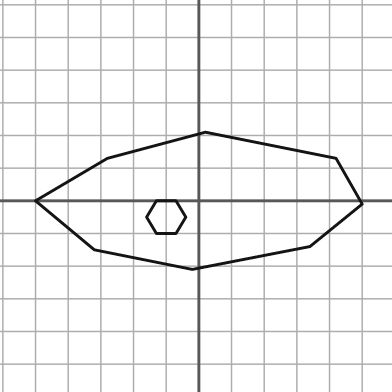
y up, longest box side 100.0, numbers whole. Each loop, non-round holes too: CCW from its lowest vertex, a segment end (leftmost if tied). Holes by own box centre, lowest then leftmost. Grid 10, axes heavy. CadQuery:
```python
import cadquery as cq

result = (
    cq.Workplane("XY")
    .moveTo(-2.0, -21.0)
    .lineTo(34.0, -14.0)
    .lineTo(50.0, -1.0)
    .lineTo(42.0, 13.0)
    .lineTo(2.0, 21.0)
    .lineTo(-28.0, 13.0)
    .lineTo(-50.0, 0.0)
    .lineTo(-32.0, -15.0)
    .close()
    .moveTo(-13.0, -10.0)
    .lineTo(-7.0, -10.0)
    .lineTo(-4.0, -5.0)
    .lineTo(-7.0, 0.0)
    .lineTo(-13.0, 0.0)
    .lineTo(-16.0, -5.0)
    .close()
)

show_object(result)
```